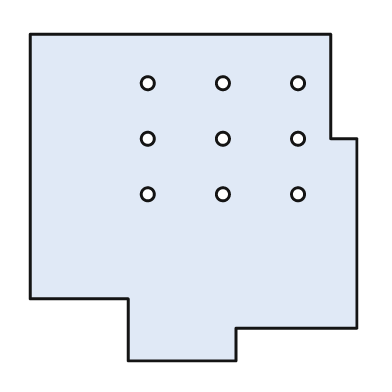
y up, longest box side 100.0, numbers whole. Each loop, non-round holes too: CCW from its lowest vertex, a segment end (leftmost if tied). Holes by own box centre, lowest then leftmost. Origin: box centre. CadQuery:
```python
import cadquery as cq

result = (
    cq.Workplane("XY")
    .moveTo(-20.0, -50.0)
    .lineTo(13.0, -50.0)
    .lineTo(13.0, -40.0)
    .lineTo(50.0, -40.0)
    .lineTo(50.0, 18.0)
    .lineTo(42.0, 18.0)
    .lineTo(42.0, 50.0)
    .lineTo(-50.0, 50.0)
    .lineTo(-50.0, -31.0)
    .lineTo(-20.0, -31.0)
    .close()
    .moveTo(-14.0, 1.0)
    .circle(2.0)
    .moveTo(9.0, 1.0)
    .circle(2.0)
    .moveTo(32.0, 1.0)
    .circle(2.0)
    .moveTo(-14.0, 18.0)
    .circle(2.0)
    .moveTo(9.0, 18.0)
    .circle(2.0)
    .moveTo(32.0, 18.0)
    .circle(2.0)
    .moveTo(-14.0, 35.0)
    .circle(2.0)
    .moveTo(9.0, 35.0)
    .circle(2.0)
    .moveTo(32.0, 35.0)
    .circle(2.0)
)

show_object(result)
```